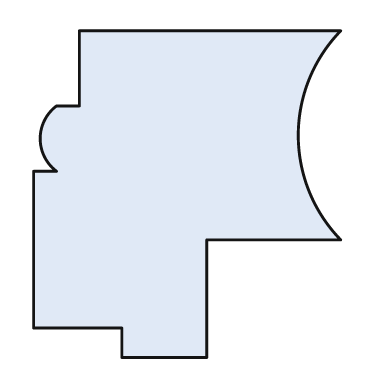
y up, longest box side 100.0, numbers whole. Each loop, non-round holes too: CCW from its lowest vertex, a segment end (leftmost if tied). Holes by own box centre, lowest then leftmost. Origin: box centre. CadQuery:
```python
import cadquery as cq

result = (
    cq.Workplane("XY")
    .moveTo(-20.0, -50.0)
    .lineTo(6.0, -50.0)
    .lineTo(6.0, -14.0)
    .lineTo(47.0, -14.0)
    .threePointArc((34.0, 18.0), (47.0, 50.0))
    .lineTo(-33.0, 50.0)
    .lineTo(-33.0, 27.0)
    .lineTo(-40.0, 27.0)
    .threePointArc((-45.0, 17.0), (-40.0, 7.0))
    .lineTo(-47.0, 7.0)
    .lineTo(-47.0, -41.0)
    .lineTo(-20.0, -41.0)
    .close()
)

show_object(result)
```